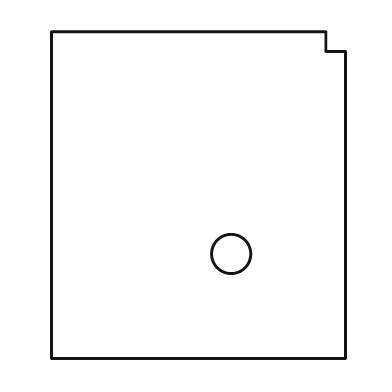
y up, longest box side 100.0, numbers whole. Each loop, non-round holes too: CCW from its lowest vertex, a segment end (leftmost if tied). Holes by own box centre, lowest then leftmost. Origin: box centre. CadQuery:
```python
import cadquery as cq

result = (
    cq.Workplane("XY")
    .moveTo(-45.0, -50.0)
    .lineTo(45.0, -50.0)
    .lineTo(45.0, 44.0)
    .lineTo(39.0, 44.0)
    .lineTo(39.0, 50.0)
    .lineTo(-45.0, 50.0)
    .close()
    .moveTo(10.0, -18.0)
    .circle(6.0)
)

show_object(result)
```